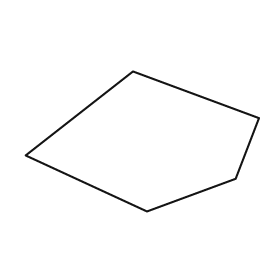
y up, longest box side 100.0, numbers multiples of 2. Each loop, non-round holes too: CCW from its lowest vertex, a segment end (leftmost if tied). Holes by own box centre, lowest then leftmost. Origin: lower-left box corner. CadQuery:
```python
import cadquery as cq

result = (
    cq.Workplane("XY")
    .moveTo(52.0, 0.0)
    .lineTo(90.0, 14.0)
    .lineTo(100.0, 40.0)
    .lineTo(46.0, 60.0)
    .lineTo(0.0, 24.0)
    .close()
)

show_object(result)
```